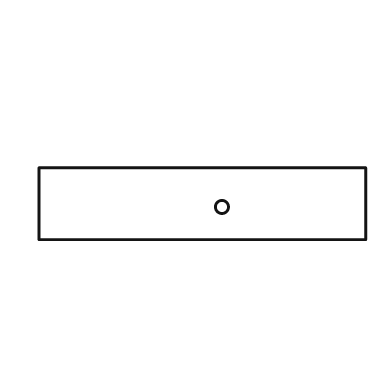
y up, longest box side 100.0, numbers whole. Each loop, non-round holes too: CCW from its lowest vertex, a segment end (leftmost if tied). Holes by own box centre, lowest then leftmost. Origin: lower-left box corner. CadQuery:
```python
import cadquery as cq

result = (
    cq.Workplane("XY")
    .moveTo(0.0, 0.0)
    .lineTo(100.0, 0.0)
    .lineTo(100.0, 22.0)
    .lineTo(0.0, 22.0)
    .close()
    .moveTo(56.0, 10.0)
    .circle(2.0)
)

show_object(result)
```